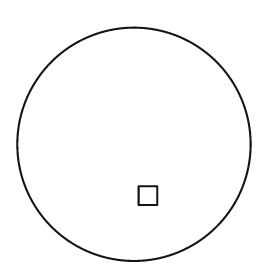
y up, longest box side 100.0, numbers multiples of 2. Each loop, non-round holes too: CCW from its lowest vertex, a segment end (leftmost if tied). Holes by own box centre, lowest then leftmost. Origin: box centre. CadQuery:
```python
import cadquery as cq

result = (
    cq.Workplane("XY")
    .moveTo(0.0, 0.0)
    .circle(50.0)
    .moveTo(2.0, -26.0)
    .lineTo(10.0, -26.0)
    .lineTo(10.0, -18.0)
    .lineTo(2.0, -18.0)
    .close()
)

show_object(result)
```